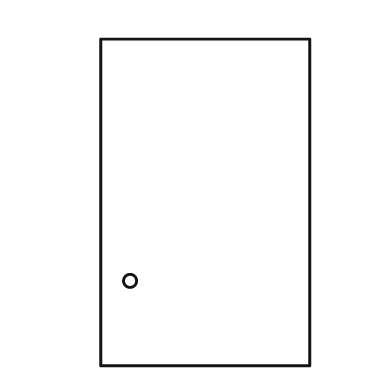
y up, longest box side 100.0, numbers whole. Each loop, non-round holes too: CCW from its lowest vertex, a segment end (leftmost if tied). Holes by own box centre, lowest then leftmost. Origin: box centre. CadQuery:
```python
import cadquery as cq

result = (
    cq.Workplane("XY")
    .moveTo(-32.0, -50.0)
    .lineTo(32.0, -50.0)
    .lineTo(32.0, 50.0)
    .lineTo(-32.0, 50.0)
    .close()
    .moveTo(-23.0, -24.0)
    .circle(2.0)
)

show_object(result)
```